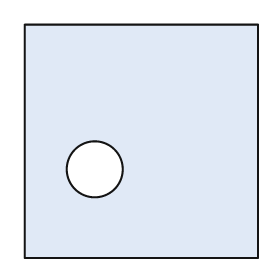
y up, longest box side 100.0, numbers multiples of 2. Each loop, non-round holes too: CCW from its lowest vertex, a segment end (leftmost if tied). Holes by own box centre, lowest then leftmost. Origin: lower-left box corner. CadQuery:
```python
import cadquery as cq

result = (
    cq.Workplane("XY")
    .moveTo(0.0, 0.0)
    .lineTo(100.0, 0.0)
    .lineTo(100.0, 100.0)
    .lineTo(0.0, 100.0)
    .close()
    .moveTo(30.0, 38.0)
    .circle(12.0)
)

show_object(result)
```